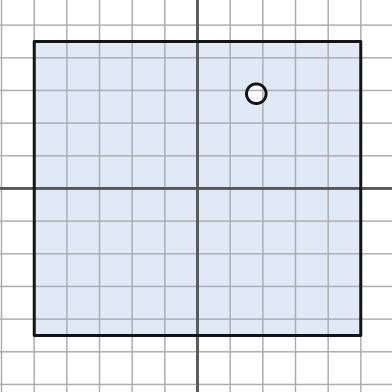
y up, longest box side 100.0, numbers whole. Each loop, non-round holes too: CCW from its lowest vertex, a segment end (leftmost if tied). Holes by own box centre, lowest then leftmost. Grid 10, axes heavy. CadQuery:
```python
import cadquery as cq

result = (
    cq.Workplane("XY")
    .moveTo(-50.0, -45.0)
    .lineTo(50.0, -45.0)
    .lineTo(50.0, 45.0)
    .lineTo(-50.0, 45.0)
    .close()
    .moveTo(18.0, 29.0)
    .circle(3.0)
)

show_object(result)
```